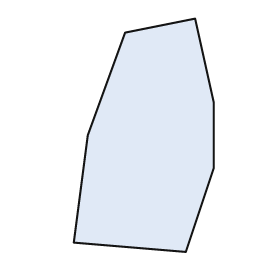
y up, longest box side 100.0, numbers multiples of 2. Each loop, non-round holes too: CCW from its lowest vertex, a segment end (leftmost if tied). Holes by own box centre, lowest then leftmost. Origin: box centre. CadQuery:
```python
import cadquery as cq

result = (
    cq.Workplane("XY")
    .moveTo(18.0, -50.0)
    .lineTo(30.0, -14.0)
    .lineTo(30.0, 14.0)
    .lineTo(22.0, 50.0)
    .lineTo(-8.0, 44.0)
    .lineTo(-24.0, 0.0)
    .lineTo(-30.0, -46.0)
    .close()
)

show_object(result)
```